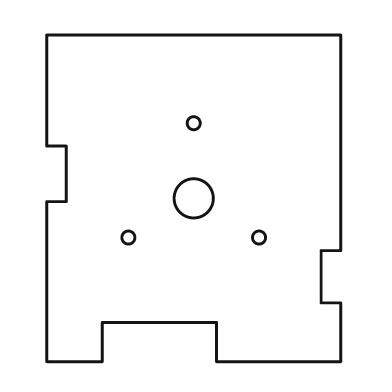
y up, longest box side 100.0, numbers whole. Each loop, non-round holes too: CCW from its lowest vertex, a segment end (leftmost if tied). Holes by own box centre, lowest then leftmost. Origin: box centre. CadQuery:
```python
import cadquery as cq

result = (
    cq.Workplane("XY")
    .moveTo(-45.0, -50.0)
    .lineTo(-28.0, -50.0)
    .lineTo(-28.0, -38.0)
    .lineTo(7.0, -38.0)
    .lineTo(7.0, -50.0)
    .lineTo(45.0, -50.0)
    .lineTo(45.0, -32.0)
    .lineTo(39.0, -32.0)
    .lineTo(39.0, -16.0)
    .lineTo(45.0, -16.0)
    .lineTo(45.0, 50.0)
    .lineTo(-45.0, 50.0)
    .lineTo(-45.0, 16.0)
    .lineTo(-39.0, 16.0)
    .lineTo(-39.0, -1.0)
    .lineTo(-45.0, -1.0)
    .close()
    .moveTo(-20.0, -12.0)
    .circle(2.0)
    .moveTo(20.0, -12.0)
    .circle(2.0)
    .moveTo(0.0, 0.0)
    .circle(6.0)
    .moveTo(0.0, 23.0)
    .circle(2.0)
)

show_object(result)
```